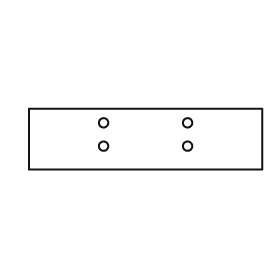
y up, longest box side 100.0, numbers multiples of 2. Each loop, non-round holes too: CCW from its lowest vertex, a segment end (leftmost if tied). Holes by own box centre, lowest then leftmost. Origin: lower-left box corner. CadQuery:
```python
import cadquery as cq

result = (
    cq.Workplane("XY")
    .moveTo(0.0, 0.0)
    .lineTo(100.0, 0.0)
    .lineTo(100.0, 26.0)
    .lineTo(0.0, 26.0)
    .close()
    .moveTo(32.0, 10.0)
    .circle(2.0)
    .moveTo(68.0, 10.0)
    .circle(2.0)
    .moveTo(32.0, 20.0)
    .circle(2.0)
    .moveTo(68.0, 20.0)
    .circle(2.0)
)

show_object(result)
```